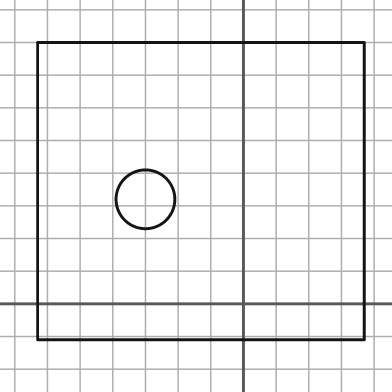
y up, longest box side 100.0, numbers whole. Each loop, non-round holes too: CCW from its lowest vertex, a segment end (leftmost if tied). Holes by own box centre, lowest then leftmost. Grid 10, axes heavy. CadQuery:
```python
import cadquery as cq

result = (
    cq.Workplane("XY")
    .moveTo(-63.0, -11.0)
    .lineTo(37.0, -11.0)
    .lineTo(37.0, 80.0)
    .lineTo(-63.0, 80.0)
    .close()
    .moveTo(-30.0, 32.0)
    .circle(9.0)
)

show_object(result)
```